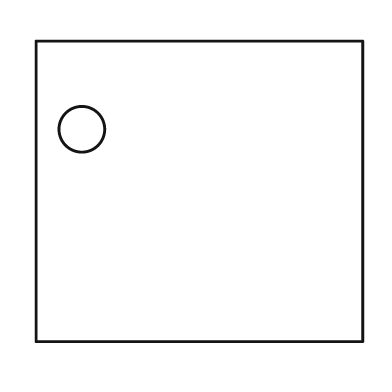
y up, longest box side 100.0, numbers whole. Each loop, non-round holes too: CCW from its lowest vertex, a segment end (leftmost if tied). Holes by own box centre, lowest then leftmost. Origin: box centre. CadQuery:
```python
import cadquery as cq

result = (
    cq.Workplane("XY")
    .moveTo(-50.0, -46.0)
    .lineTo(50.0, -46.0)
    .lineTo(50.0, 46.0)
    .lineTo(-50.0, 46.0)
    .close()
    .moveTo(-36.0, 19.0)
    .circle(7.0)
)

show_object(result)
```